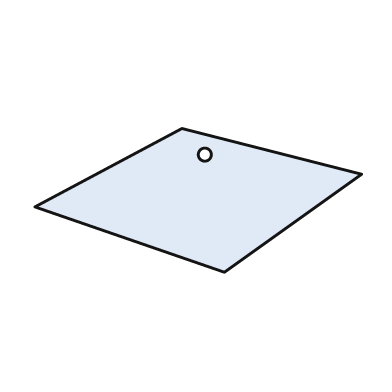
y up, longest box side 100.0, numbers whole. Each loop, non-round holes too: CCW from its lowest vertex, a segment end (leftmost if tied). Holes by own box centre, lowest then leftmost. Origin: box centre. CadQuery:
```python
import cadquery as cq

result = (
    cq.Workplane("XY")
    .moveTo(8.0, -22.0)
    .lineTo(50.0, 8.0)
    .lineTo(-5.0, 22.0)
    .lineTo(-50.0, -2.0)
    .close()
    .moveTo(2.0, 14.0)
    .circle(2.0)
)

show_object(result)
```